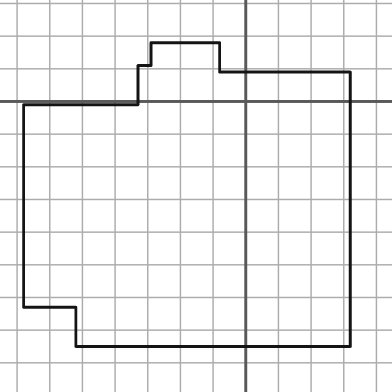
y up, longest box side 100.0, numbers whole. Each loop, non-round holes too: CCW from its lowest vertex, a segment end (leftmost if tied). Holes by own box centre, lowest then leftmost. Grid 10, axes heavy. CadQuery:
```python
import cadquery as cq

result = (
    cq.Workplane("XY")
    .moveTo(-52.0, -75.0)
    .lineTo(32.0, -75.0)
    .lineTo(32.0, 9.0)
    .lineTo(-8.0, 9.0)
    .lineTo(-8.0, 18.0)
    .lineTo(-29.0, 18.0)
    .lineTo(-29.0, 11.0)
    .lineTo(-33.0, 11.0)
    .lineTo(-33.0, -1.0)
    .lineTo(-68.0, -1.0)
    .lineTo(-68.0, -63.0)
    .lineTo(-52.0, -63.0)
    .close()
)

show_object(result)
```